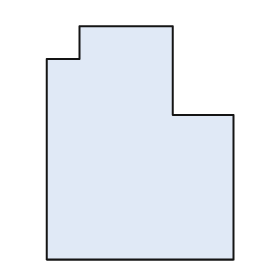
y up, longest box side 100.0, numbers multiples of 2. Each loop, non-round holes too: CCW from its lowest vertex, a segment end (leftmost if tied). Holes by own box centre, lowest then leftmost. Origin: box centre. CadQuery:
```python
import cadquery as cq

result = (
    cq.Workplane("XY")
    .moveTo(-40.0, -50.0)
    .lineTo(40.0, -50.0)
    .lineTo(40.0, 12.0)
    .lineTo(14.0, 12.0)
    .lineTo(14.0, 50.0)
    .lineTo(-26.0, 50.0)
    .lineTo(-26.0, 36.0)
    .lineTo(-40.0, 36.0)
    .close()
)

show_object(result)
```